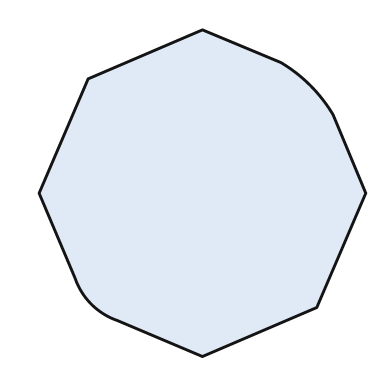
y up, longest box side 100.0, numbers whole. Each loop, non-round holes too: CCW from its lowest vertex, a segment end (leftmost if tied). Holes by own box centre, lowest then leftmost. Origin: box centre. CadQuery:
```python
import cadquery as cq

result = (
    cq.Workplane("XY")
    .moveTo(0.0, -50.0)
    .lineTo(35.0, -35.0)
    .lineTo(50.0, 0.0)
    .lineTo(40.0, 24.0)
    .threePointArc((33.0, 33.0), (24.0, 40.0))
    .lineTo(0.0, 50.0)
    .lineTo(-35.0, 35.0)
    .lineTo(-50.0, 0.0)
    .lineTo(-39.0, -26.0)
    .threePointArc((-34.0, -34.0), (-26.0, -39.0))
    .close()
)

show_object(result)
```